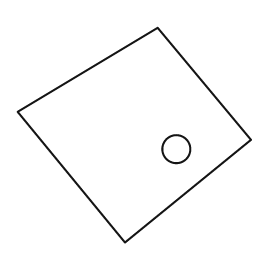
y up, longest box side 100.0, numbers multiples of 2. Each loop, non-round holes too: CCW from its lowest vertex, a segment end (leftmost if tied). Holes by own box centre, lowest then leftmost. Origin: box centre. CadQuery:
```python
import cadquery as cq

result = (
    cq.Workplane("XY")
    .moveTo(-4.0, -46.0)
    .lineTo(50.0, -2.0)
    .lineTo(10.0, 46.0)
    .lineTo(-50.0, 10.0)
    .close()
    .moveTo(18.0, -6.0)
    .circle(6.0)
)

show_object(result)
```